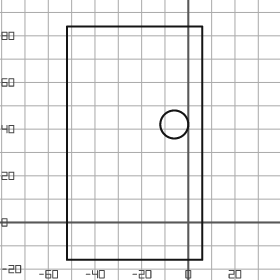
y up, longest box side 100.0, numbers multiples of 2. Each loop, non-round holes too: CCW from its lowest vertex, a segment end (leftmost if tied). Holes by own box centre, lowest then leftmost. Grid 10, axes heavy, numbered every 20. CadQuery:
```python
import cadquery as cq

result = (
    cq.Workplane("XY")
    .moveTo(-52.0, -16.0)
    .lineTo(6.0, -16.0)
    .lineTo(6.0, 84.0)
    .lineTo(-52.0, 84.0)
    .close()
    .moveTo(-6.0, 42.0)
    .circle(6.0)
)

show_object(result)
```